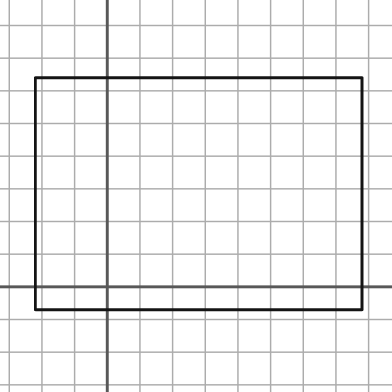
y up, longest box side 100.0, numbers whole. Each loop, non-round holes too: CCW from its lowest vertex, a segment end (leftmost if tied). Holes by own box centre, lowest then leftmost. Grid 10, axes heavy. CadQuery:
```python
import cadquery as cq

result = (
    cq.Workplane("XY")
    .moveTo(-22.0, -7.0)
    .lineTo(78.0, -7.0)
    .lineTo(78.0, 64.0)
    .lineTo(-22.0, 64.0)
    .close()
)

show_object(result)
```